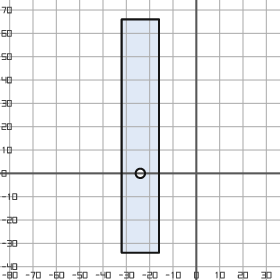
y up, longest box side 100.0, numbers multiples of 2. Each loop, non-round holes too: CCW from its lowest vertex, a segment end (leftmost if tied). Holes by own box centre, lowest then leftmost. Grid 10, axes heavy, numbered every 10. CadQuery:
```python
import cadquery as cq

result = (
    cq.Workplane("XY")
    .moveTo(-32.0, -34.0)
    .lineTo(-16.0, -34.0)
    .lineTo(-16.0, 66.0)
    .lineTo(-32.0, 66.0)
    .close()
    .moveTo(-24.0, 0.0)
    .circle(2.0)
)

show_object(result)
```